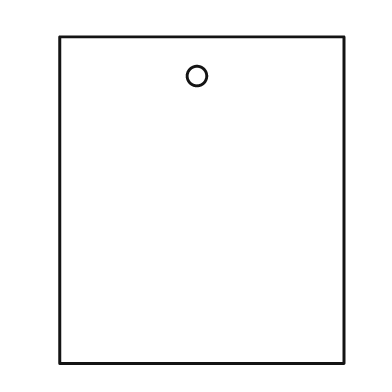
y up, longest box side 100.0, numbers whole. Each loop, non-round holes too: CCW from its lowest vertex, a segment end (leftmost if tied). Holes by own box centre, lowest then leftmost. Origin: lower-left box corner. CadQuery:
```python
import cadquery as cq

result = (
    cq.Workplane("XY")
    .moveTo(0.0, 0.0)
    .lineTo(87.0, 0.0)
    .lineTo(87.0, 100.0)
    .lineTo(0.0, 100.0)
    .close()
    .moveTo(42.0, 88.0)
    .circle(3.0)
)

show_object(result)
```